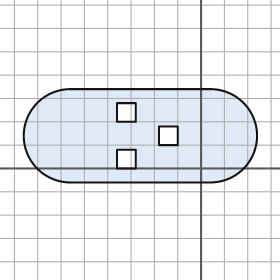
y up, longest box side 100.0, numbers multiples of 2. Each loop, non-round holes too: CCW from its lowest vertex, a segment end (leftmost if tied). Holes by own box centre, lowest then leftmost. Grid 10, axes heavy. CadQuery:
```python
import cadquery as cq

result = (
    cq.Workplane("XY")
    .moveTo(-56.0, -6.0)
    .lineTo(4.0, -6.0)
    .threePointArc((24.0, 14.0), (4.0, 34.0))
    .lineTo(-56.0, 34.0)
    .threePointArc((-76.0, 14.0), (-56.0, -6.0))
    .close()
    .moveTo(-36.0, 0.0)
    .lineTo(-28.0, 0.0)
    .lineTo(-28.0, 8.0)
    .lineTo(-36.0, 8.0)
    .close()
    .moveTo(-18.0, 10.0)
    .lineTo(-10.0, 10.0)
    .lineTo(-10.0, 18.0)
    .lineTo(-18.0, 18.0)
    .close()
    .moveTo(-36.0, 20.0)
    .lineTo(-28.0, 20.0)
    .lineTo(-28.0, 28.0)
    .lineTo(-36.0, 28.0)
    .close()
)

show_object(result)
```